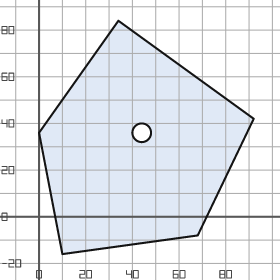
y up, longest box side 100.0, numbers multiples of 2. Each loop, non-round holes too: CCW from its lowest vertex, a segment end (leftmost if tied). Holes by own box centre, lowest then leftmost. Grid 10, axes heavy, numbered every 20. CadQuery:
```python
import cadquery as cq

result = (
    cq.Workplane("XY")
    .moveTo(10.0, -16.0)
    .lineTo(68.0, -8.0)
    .lineTo(92.0, 42.0)
    .lineTo(34.0, 84.0)
    .lineTo(0.0, 36.0)
    .close()
    .moveTo(44.0, 36.0)
    .circle(4.0)
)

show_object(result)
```